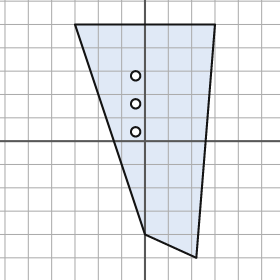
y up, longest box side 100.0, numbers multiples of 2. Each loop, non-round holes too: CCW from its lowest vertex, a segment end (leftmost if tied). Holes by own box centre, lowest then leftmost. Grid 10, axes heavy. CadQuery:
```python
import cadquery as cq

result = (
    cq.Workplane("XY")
    .moveTo(22.0, -50.0)
    .lineTo(30.0, 50.0)
    .lineTo(-30.0, 50.0)
    .lineTo(0.0, -40.0)
    .close()
    .moveTo(-4.0, 4.0)
    .circle(2.0)
    .moveTo(-4.0, 16.0)
    .circle(2.0)
    .moveTo(-4.0, 28.0)
    .circle(2.0)
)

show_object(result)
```